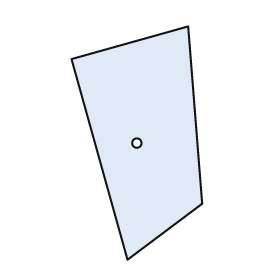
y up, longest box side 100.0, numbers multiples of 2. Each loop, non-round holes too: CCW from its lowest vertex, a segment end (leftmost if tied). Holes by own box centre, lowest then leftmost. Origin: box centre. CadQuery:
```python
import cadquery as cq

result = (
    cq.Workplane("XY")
    .moveTo(-4.0, -50.0)
    .lineTo(28.0, -26.0)
    .lineTo(22.0, 50.0)
    .lineTo(-28.0, 36.0)
    .close()
    .moveTo(0.0, 0.0)
    .circle(2.0)
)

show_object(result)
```